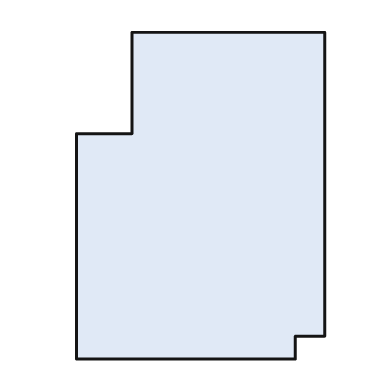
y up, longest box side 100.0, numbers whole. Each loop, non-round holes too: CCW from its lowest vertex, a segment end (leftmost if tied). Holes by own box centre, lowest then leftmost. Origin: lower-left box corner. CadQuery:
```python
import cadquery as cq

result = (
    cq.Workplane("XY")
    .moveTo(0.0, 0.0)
    .lineTo(67.0, 0.0)
    .lineTo(67.0, 7.0)
    .lineTo(76.0, 7.0)
    .lineTo(76.0, 100.0)
    .lineTo(17.0, 100.0)
    .lineTo(17.0, 69.0)
    .lineTo(0.0, 69.0)
    .close()
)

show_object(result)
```